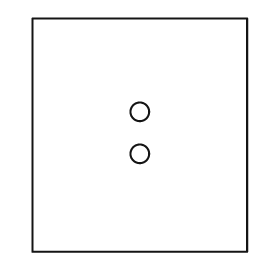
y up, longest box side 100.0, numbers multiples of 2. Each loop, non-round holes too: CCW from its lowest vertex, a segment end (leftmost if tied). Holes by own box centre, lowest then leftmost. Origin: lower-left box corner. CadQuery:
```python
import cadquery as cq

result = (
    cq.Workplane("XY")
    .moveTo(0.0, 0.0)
    .lineTo(92.0, 0.0)
    .lineTo(92.0, 100.0)
    .lineTo(0.0, 100.0)
    .close()
    .moveTo(46.0, 42.0)
    .circle(4.0)
    .moveTo(46.0, 60.0)
    .circle(4.0)
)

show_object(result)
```